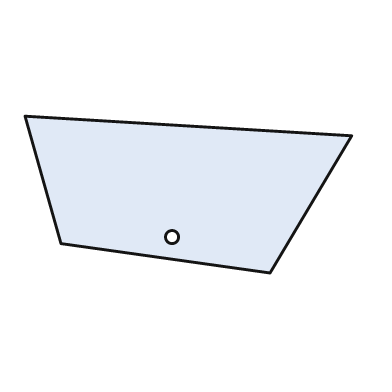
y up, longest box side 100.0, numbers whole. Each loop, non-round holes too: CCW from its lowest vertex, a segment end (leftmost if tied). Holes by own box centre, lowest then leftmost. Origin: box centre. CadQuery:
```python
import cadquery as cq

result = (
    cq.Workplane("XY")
    .moveTo(25.0, -24.0)
    .lineTo(50.0, 18.0)
    .lineTo(-50.0, 24.0)
    .lineTo(-39.0, -15.0)
    .close()
    .moveTo(-5.0, -13.0)
    .circle(2.0)
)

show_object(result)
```